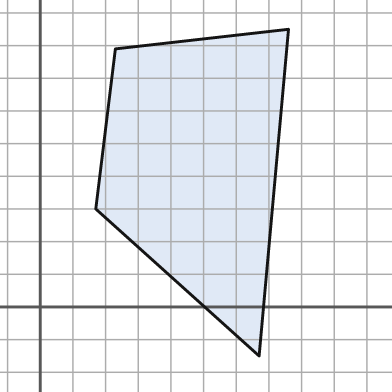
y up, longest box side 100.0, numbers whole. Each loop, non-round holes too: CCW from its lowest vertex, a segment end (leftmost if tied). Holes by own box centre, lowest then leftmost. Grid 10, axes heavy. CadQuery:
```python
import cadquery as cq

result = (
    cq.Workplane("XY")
    .moveTo(67.0, -15.0)
    .lineTo(76.0, 85.0)
    .lineTo(23.0, 79.0)
    .lineTo(17.0, 30.0)
    .close()
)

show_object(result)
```